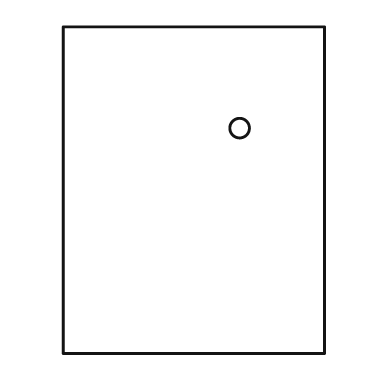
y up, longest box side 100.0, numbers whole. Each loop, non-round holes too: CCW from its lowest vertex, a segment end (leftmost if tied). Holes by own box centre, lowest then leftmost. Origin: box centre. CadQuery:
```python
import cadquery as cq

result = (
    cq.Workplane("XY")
    .moveTo(-40.0, -50.0)
    .lineTo(40.0, -50.0)
    .lineTo(40.0, 50.0)
    .lineTo(-40.0, 50.0)
    .close()
    .moveTo(14.0, 19.0)
    .circle(3.0)
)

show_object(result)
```